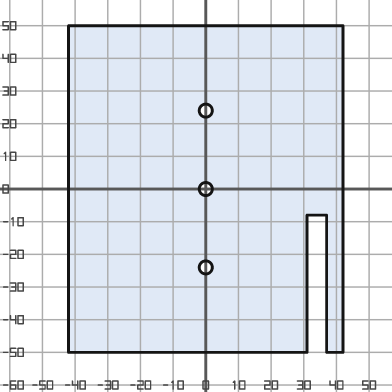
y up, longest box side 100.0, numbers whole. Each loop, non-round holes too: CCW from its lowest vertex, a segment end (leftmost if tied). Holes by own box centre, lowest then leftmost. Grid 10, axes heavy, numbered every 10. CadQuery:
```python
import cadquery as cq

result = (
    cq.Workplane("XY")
    .moveTo(-42.0, -50.0)
    .lineTo(31.0, -50.0)
    .lineTo(31.0, -8.0)
    .lineTo(37.0, -8.0)
    .lineTo(37.0, -50.0)
    .lineTo(42.0, -50.0)
    .lineTo(42.0, 50.0)
    .lineTo(-42.0, 50.0)
    .close()
    .moveTo(0.0, -24.0)
    .circle(2.0)
    .moveTo(0.0, 0.0)
    .circle(2.0)
    .moveTo(0.0, 24.0)
    .circle(2.0)
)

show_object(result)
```